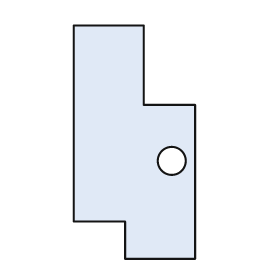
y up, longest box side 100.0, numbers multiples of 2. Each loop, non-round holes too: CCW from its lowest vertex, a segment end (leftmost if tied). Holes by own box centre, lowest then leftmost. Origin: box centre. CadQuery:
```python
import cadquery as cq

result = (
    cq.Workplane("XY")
    .moveTo(-4.0, -50.0)
    .lineTo(26.0, -50.0)
    .lineTo(26.0, 16.0)
    .lineTo(4.0, 16.0)
    .lineTo(4.0, 50.0)
    .lineTo(-26.0, 50.0)
    .lineTo(-26.0, -34.0)
    .lineTo(-4.0, -34.0)
    .close()
    .moveTo(16.0, -8.0)
    .circle(6.0)
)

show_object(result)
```